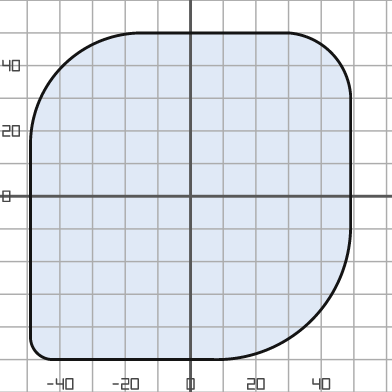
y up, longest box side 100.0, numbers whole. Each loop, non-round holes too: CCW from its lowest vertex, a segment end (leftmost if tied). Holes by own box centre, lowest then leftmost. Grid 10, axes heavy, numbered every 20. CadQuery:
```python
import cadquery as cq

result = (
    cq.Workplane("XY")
    .moveTo(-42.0, -50.0)
    .lineTo(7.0, -50.0)
    .threePointArc((37.0, -38.0), (49.0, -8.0))
    .lineTo(49.0, 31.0)
    .threePointArc((43.0, 44.0), (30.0, 50.0))
    .lineTo(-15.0, 50.0)
    .threePointArc((-39.0, 40.0), (-49.0, 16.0))
    .lineTo(-49.0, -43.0)
    .threePointArc((-47.0, -48.0), (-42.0, -50.0))
    .close()
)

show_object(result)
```